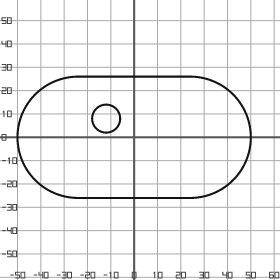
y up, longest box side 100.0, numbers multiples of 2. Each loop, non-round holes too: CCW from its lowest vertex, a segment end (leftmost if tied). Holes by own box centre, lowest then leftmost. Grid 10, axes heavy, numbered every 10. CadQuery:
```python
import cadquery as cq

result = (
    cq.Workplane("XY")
    .moveTo(-24.0, -26.0)
    .lineTo(24.0, -26.0)
    .threePointArc((50.0, 0.0), (24.0, 26.0))
    .lineTo(-24.0, 26.0)
    .threePointArc((-50.0, 0.0), (-24.0, -26.0))
    .close()
    .moveTo(-12.0, 8.0)
    .circle(6.0)
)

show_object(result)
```